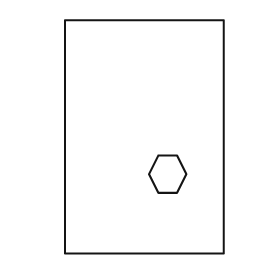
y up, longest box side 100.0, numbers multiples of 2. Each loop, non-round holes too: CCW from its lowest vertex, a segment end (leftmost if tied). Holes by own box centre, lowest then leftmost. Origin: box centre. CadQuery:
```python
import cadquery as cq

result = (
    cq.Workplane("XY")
    .moveTo(-34.0, -50.0)
    .lineTo(34.0, -50.0)
    .lineTo(34.0, 50.0)
    .lineTo(-34.0, 50.0)
    .close()
    .moveTo(6.0, -24.0)
    .lineTo(14.0, -24.0)
    .lineTo(18.0, -16.0)
    .lineTo(14.0, -8.0)
    .lineTo(6.0, -8.0)
    .lineTo(2.0, -16.0)
    .close()
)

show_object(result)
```